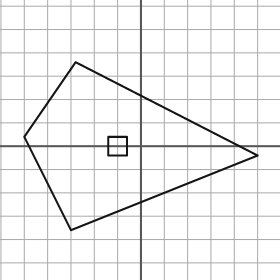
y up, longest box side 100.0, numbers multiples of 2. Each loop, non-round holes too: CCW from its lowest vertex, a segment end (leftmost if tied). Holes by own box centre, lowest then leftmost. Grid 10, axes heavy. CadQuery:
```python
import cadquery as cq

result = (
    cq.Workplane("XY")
    .moveTo(-30.0, -36.0)
    .lineTo(50.0, -4.0)
    .lineTo(-28.0, 36.0)
    .lineTo(-50.0, 4.0)
    .close()
    .moveTo(-14.0, -4.0)
    .lineTo(-6.0, -4.0)
    .lineTo(-6.0, 4.0)
    .lineTo(-14.0, 4.0)
    .close()
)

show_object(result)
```